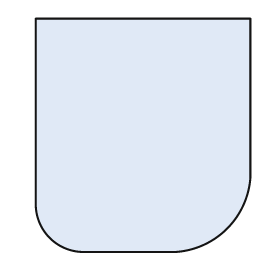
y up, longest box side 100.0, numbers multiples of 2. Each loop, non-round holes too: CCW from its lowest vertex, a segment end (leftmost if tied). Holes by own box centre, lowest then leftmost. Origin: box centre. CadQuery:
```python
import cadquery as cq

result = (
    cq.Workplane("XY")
    .moveTo(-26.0, -50.0)
    .lineTo(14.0, -50.0)
    .threePointArc((36.0, -40.0), (46.0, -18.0))
    .lineTo(46.0, 50.0)
    .lineTo(-46.0, 50.0)
    .lineTo(-46.0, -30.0)
    .threePointArc((-40.0, -44.0), (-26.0, -50.0))
    .close()
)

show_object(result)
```